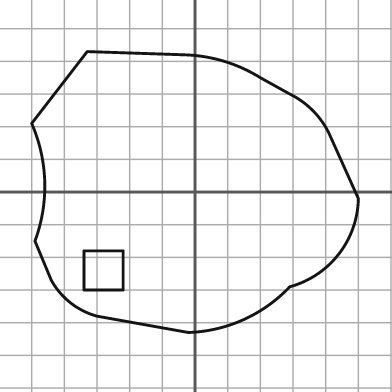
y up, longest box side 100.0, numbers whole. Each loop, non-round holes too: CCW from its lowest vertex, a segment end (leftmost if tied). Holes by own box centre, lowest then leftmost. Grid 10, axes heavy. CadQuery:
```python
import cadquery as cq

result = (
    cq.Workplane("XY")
    .moveTo(-2.0, -43.0)
    .threePointArc((15.0, -39.0), (29.0, -29.0))
    .threePointArc((44.0, -19.0), (50.0, -2.0))
    .lineTo(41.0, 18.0)
    .threePointArc((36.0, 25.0), (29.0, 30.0))
    .lineTo(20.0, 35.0)
    .threePointArc((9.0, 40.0), (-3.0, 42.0))
    .lineTo(-33.0, 43.0)
    .lineTo(-50.0, 21.0)
    .threePointArc((-46.0, 3.0), (-49.0, -15.0))
    .lineTo(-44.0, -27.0)
    .threePointArc((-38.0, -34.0), (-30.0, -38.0))
    .close()
    .moveTo(-34.0, -30.0)
    .lineTo(-22.0, -30.0)
    .lineTo(-22.0, -18.0)
    .lineTo(-34.0, -18.0)
    .close()
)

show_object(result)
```